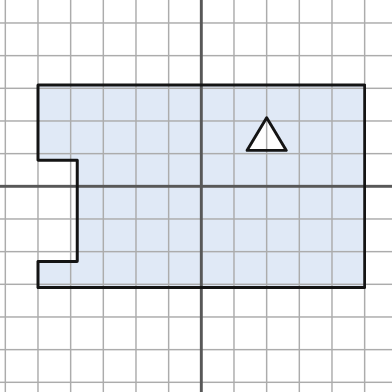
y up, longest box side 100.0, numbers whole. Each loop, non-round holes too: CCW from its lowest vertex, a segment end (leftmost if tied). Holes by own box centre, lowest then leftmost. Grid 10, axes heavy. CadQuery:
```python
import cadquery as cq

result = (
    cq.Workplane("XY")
    .moveTo(-50.0, -31.0)
    .lineTo(50.0, -31.0)
    .lineTo(50.0, 31.0)
    .lineTo(-50.0, 31.0)
    .lineTo(-50.0, 8.0)
    .lineTo(-38.0, 8.0)
    .lineTo(-38.0, -23.0)
    .lineTo(-50.0, -23.0)
    .close()
    .moveTo(14.0, 11.0)
    .lineTo(26.0, 11.0)
    .lineTo(20.0, 21.0)
    .close()
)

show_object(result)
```